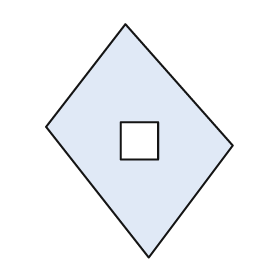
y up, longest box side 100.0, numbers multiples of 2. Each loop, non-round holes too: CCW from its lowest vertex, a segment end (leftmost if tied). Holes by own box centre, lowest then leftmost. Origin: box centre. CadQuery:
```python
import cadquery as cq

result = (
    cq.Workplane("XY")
    .moveTo(4.0, -50.0)
    .lineTo(40.0, -2.0)
    .lineTo(-6.0, 50.0)
    .lineTo(-40.0, 6.0)
    .close()
    .moveTo(-8.0, -8.0)
    .lineTo(8.0, -8.0)
    .lineTo(8.0, 8.0)
    .lineTo(-8.0, 8.0)
    .close()
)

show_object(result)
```